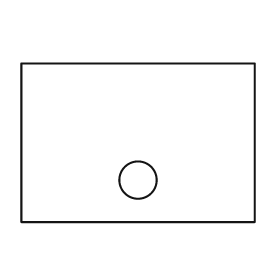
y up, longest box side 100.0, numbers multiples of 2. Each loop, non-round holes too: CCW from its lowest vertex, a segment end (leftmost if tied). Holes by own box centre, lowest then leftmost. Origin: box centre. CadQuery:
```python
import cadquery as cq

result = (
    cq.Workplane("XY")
    .moveTo(-50.0, -34.0)
    .lineTo(50.0, -34.0)
    .lineTo(50.0, 34.0)
    .lineTo(-50.0, 34.0)
    .close()
    .moveTo(0.0, -16.0)
    .circle(8.0)
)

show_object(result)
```